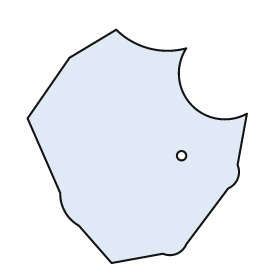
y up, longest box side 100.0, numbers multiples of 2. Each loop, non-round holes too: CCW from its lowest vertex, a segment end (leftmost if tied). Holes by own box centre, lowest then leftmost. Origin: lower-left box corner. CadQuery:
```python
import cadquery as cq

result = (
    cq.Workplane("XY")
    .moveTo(36.0, 0.0)
    .lineTo(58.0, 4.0)
    .threePointArc((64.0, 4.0), (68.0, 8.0))
    .lineTo(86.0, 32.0)
    .threePointArc((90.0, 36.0), (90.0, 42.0))
    .lineTo(94.0, 64.0)
    .threePointArc((70.0, 68.0), (68.0, 92.0))
    .threePointArc((52.0, 92.0), (38.0, 100.0))
    .lineTo(18.0, 88.0)
    .lineTo(0.0, 62.0)
    .lineTo(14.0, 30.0)
    .threePointArc((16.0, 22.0), (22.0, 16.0))
    .close()
    .moveTo(66.0, 46.0)
    .circle(2.0)
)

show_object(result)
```